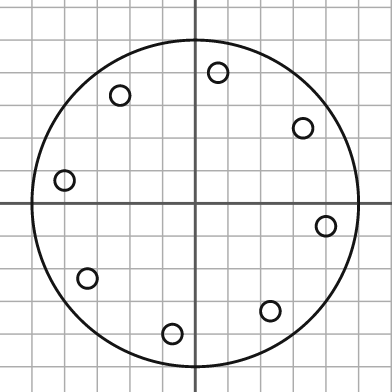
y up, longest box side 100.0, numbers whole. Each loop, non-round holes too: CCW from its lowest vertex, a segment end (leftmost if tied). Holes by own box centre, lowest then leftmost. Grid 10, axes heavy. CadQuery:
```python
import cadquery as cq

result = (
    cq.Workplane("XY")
    .moveTo(0.0, 0.0)
    .circle(50.0)
    .moveTo(-7.0, -40.0)
    .circle(3.0)
    .moveTo(23.0, -33.0)
    .circle(3.0)
    .moveTo(-33.0, -23.0)
    .circle(3.0)
    .moveTo(40.0, -7.0)
    .circle(3.0)
    .moveTo(-40.0, 7.0)
    .circle(3.0)
    .moveTo(33.0, 23.0)
    .circle(3.0)
    .moveTo(-23.0, 33.0)
    .circle(3.0)
    .moveTo(7.0, 40.0)
    .circle(3.0)
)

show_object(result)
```